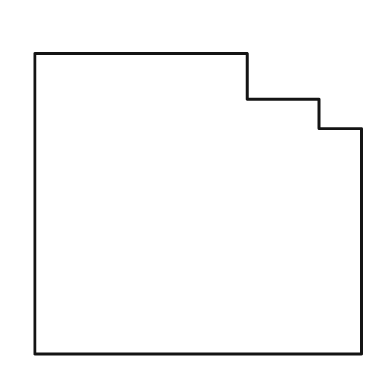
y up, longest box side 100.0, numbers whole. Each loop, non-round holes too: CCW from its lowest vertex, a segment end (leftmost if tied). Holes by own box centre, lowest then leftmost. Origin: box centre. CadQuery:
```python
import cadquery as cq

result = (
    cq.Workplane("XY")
    .moveTo(-50.0, -46.0)
    .lineTo(50.0, -46.0)
    .lineTo(50.0, 23.0)
    .lineTo(37.0, 23.0)
    .lineTo(37.0, 32.0)
    .lineTo(15.0, 32.0)
    .lineTo(15.0, 46.0)
    .lineTo(-50.0, 46.0)
    .close()
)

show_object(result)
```